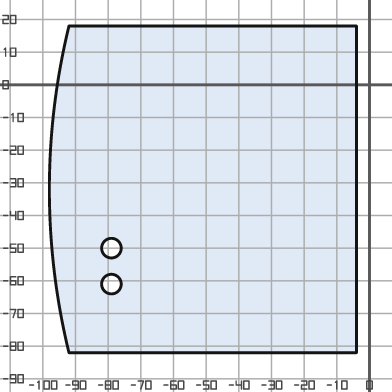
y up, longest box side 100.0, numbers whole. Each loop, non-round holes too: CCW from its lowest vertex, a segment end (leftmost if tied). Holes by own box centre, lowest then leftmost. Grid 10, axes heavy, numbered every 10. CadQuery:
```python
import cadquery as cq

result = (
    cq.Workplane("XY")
    .moveTo(-92.0, -82.0)
    .lineTo(-4.0, -82.0)
    .lineTo(-4.0, 18.0)
    .lineTo(-92.0, 18.0)
    .threePointArc((-98.0, -32.0), (-92.0, -82.0))
    .close()
    .moveTo(-79.0, -61.0)
    .circle(3.0)
    .moveTo(-79.0, -50.0)
    .circle(3.0)
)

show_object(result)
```